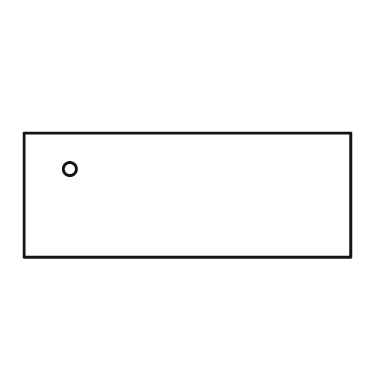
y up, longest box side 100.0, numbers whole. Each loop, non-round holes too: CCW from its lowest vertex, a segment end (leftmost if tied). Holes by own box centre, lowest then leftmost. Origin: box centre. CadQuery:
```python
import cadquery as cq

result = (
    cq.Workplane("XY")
    .moveTo(-50.0, -19.0)
    .lineTo(50.0, -19.0)
    .lineTo(50.0, 19.0)
    .lineTo(-50.0, 19.0)
    .close()
    .moveTo(-36.0, 8.0)
    .circle(2.0)
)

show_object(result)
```